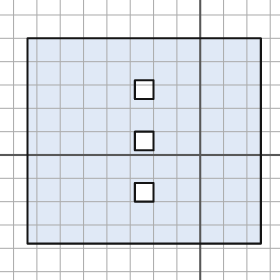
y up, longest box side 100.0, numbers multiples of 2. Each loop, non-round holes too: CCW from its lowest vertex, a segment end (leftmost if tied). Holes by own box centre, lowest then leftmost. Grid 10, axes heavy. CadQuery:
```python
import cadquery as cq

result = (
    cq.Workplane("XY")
    .moveTo(-74.0, -38.0)
    .lineTo(26.0, -38.0)
    .lineTo(26.0, 50.0)
    .lineTo(-74.0, 50.0)
    .close()
    .moveTo(-28.0, -20.0)
    .lineTo(-20.0, -20.0)
    .lineTo(-20.0, -12.0)
    .lineTo(-28.0, -12.0)
    .close()
    .moveTo(-28.0, 2.0)
    .lineTo(-20.0, 2.0)
    .lineTo(-20.0, 10.0)
    .lineTo(-28.0, 10.0)
    .close()
    .moveTo(-28.0, 24.0)
    .lineTo(-20.0, 24.0)
    .lineTo(-20.0, 32.0)
    .lineTo(-28.0, 32.0)
    .close()
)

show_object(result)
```